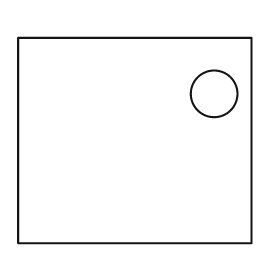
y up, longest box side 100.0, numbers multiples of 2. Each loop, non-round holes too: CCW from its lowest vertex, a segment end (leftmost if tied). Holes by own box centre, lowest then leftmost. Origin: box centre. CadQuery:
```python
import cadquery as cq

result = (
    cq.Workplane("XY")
    .moveTo(-50.0, -44.0)
    .lineTo(50.0, -44.0)
    .lineTo(50.0, 44.0)
    .lineTo(-50.0, 44.0)
    .close()
    .moveTo(34.0, 20.0)
    .circle(10.0)
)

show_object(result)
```